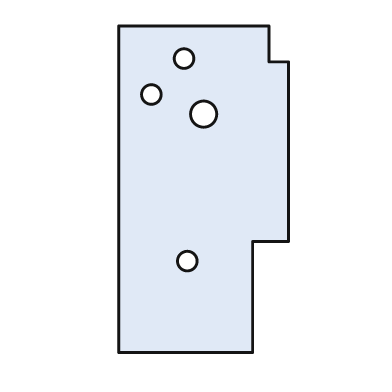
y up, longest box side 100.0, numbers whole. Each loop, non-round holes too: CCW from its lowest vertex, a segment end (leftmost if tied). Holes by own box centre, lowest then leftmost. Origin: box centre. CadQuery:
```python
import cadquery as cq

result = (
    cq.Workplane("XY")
    .moveTo(-26.0, -50.0)
    .lineTo(15.0, -50.0)
    .lineTo(15.0, -16.0)
    .lineTo(26.0, -16.0)
    .lineTo(26.0, 39.0)
    .lineTo(20.0, 39.0)
    .lineTo(20.0, 50.0)
    .lineTo(-26.0, 50.0)
    .close()
    .moveTo(-5.0, -22.0)
    .circle(3.0)
    .moveTo(0.0, 23.0)
    .circle(4.0)
    .moveTo(-16.0, 29.0)
    .circle(3.0)
    .moveTo(-6.0, 40.0)
    .circle(3.0)
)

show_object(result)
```